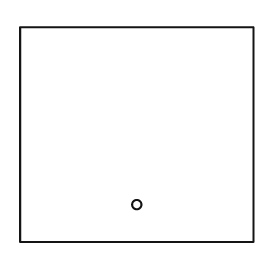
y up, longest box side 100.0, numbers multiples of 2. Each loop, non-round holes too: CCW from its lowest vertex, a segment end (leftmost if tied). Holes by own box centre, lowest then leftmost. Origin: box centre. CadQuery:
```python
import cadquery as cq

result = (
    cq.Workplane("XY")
    .moveTo(-50.0, -46.0)
    .lineTo(50.0, -46.0)
    .lineTo(50.0, 46.0)
    .lineTo(-50.0, 46.0)
    .close()
    .moveTo(0.0, -30.0)
    .circle(2.0)
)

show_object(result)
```